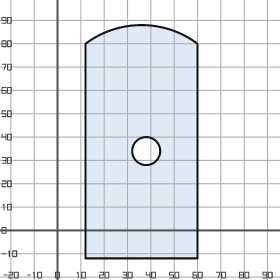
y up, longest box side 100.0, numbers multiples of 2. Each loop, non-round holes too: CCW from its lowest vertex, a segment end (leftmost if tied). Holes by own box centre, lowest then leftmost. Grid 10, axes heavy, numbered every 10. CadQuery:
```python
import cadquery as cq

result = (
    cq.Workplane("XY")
    .moveTo(12.0, -12.0)
    .lineTo(60.0, -12.0)
    .lineTo(60.0, 80.0)
    .threePointArc((36.0, 88.0), (12.0, 80.0))
    .close()
    .moveTo(38.0, 34.0)
    .circle(6.0)
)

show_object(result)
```